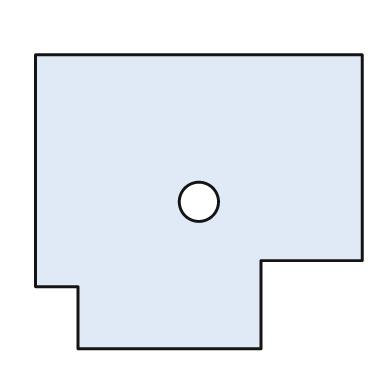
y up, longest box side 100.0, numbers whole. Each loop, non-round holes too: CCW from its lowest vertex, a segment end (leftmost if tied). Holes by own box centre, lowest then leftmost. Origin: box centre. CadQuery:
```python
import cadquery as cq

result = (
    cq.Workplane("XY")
    .moveTo(-37.0, -45.0)
    .lineTo(19.0, -45.0)
    .lineTo(19.0, -18.0)
    .lineTo(50.0, -18.0)
    .lineTo(50.0, 45.0)
    .lineTo(-50.0, 45.0)
    .lineTo(-50.0, -26.0)
    .lineTo(-37.0, -26.0)
    .close()
    .moveTo(0.0, 0.0)
    .circle(6.0)
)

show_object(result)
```